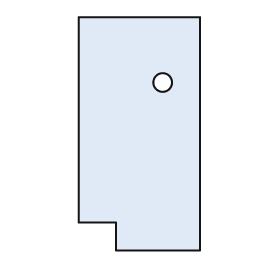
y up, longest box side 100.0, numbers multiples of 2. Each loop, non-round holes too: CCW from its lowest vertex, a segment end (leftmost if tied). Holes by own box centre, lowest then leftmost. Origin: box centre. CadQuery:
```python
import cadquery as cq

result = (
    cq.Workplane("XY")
    .moveTo(-10.0, -50.0)
    .lineTo(26.0, -50.0)
    .lineTo(26.0, 50.0)
    .lineTo(-26.0, 50.0)
    .lineTo(-26.0, -38.0)
    .lineTo(-10.0, -38.0)
    .close()
    .moveTo(10.0, 22.0)
    .circle(4.0)
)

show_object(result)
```